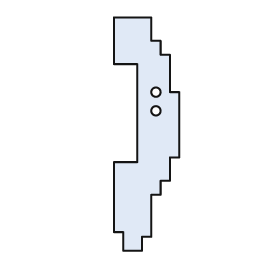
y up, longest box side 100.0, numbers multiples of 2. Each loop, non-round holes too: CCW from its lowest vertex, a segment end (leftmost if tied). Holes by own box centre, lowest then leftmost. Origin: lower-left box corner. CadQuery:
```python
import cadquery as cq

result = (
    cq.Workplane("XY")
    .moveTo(4.0, 0.0)
    .lineTo(12.0, 0.0)
    .lineTo(12.0, 6.0)
    .lineTo(16.0, 6.0)
    .lineTo(16.0, 24.0)
    .lineTo(20.0, 24.0)
    .lineTo(20.0, 30.0)
    .lineTo(24.0, 30.0)
    .lineTo(24.0, 40.0)
    .lineTo(28.0, 40.0)
    .lineTo(28.0, 68.0)
    .lineTo(24.0, 68.0)
    .lineTo(24.0, 84.0)
    .lineTo(20.0, 84.0)
    .lineTo(20.0, 90.0)
    .lineTo(16.0, 90.0)
    .lineTo(16.0, 100.0)
    .lineTo(0.0, 100.0)
    .lineTo(0.0, 80.0)
    .lineTo(10.0, 80.0)
    .lineTo(10.0, 38.0)
    .lineTo(0.0, 38.0)
    .lineTo(0.0, 8.0)
    .lineTo(4.0, 8.0)
    .close()
    .moveTo(18.0, 60.0)
    .circle(2.0)
    .moveTo(18.0, 68.0)
    .circle(2.0)
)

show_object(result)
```